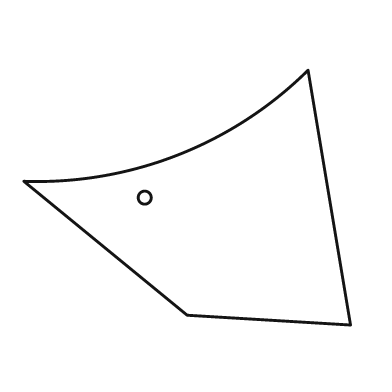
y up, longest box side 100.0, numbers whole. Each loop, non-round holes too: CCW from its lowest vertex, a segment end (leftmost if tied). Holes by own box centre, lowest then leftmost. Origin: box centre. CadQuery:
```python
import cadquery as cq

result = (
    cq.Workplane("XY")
    .moveTo(50.0, -39.0)
    .lineTo(37.0, 39.0)
    .threePointArc((-3.0, 13.0), (-50.0, 5.0))
    .lineTo(0.0, -36.0)
    .close()
    .moveTo(-13.0, 0.0)
    .circle(2.0)
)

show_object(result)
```